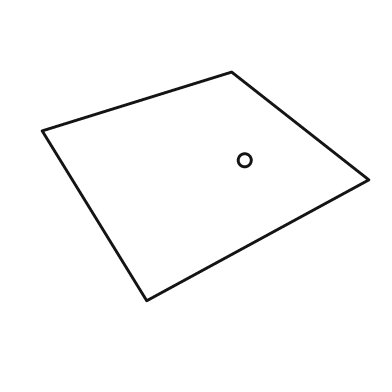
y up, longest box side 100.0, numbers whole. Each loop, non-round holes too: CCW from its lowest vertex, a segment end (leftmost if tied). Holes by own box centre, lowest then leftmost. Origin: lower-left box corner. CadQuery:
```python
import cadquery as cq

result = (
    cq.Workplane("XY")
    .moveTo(32.0, 0.0)
    .lineTo(100.0, 37.0)
    .lineTo(58.0, 70.0)
    .lineTo(0.0, 52.0)
    .close()
    .moveTo(62.0, 43.0)
    .circle(2.0)
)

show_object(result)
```